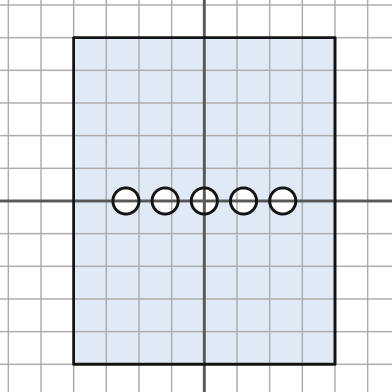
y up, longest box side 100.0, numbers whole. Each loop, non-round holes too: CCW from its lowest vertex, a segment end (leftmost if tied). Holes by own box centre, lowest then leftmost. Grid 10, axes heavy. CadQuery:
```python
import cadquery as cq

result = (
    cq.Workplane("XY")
    .moveTo(-40.0, -50.0)
    .lineTo(40.0, -50.0)
    .lineTo(40.0, 50.0)
    .lineTo(-40.0, 50.0)
    .close()
    .moveTo(-24.0, 0.0)
    .circle(4.0)
    .moveTo(-12.0, 0.0)
    .circle(4.0)
    .moveTo(0.0, 0.0)
    .circle(4.0)
    .moveTo(12.0, 0.0)
    .circle(4.0)
    .moveTo(24.0, 0.0)
    .circle(4.0)
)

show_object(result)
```